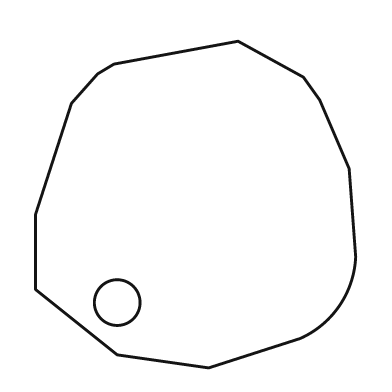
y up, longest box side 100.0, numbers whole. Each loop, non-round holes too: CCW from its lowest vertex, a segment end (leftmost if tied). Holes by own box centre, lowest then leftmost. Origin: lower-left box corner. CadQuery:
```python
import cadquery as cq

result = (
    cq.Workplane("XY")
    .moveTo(53.0, 0.0)
    .lineTo(81.0, 9.0)
    .threePointArc((93.0, 19.0), (98.0, 34.0))
    .lineTo(96.0, 61.0)
    .lineTo(87.0, 82.0)
    .lineTo(82.0, 89.0)
    .lineTo(62.0, 100.0)
    .lineTo(24.0, 93.0)
    .lineTo(19.0, 90.0)
    .lineTo(11.0, 81.0)
    .lineTo(0.0, 47.0)
    .lineTo(0.0, 24.0)
    .lineTo(25.0, 4.0)
    .close()
    .moveTo(25.0, 20.0)
    .circle(7.0)
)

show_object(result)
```